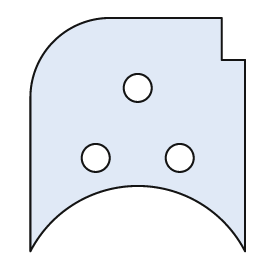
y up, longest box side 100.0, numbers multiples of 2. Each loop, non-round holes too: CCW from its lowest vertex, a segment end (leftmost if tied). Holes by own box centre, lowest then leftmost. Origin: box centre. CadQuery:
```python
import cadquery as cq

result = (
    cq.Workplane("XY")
    .moveTo(-46.0, -50.0)
    .threePointArc((0.0, -22.0), (46.0, -50.0))
    .lineTo(46.0, 32.0)
    .lineTo(36.0, 32.0)
    .lineTo(36.0, 50.0)
    .lineTo(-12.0, 50.0)
    .threePointArc((-36.0, 40.0), (-46.0, 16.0))
    .close()
    .moveTo(-18.0, -10.0)
    .circle(6.0)
    .moveTo(18.0, -10.0)
    .circle(6.0)
    .moveTo(0.0, 20.0)
    .circle(6.0)
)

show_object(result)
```